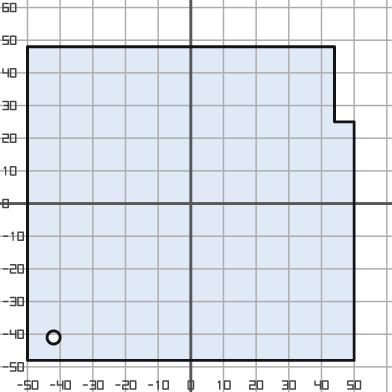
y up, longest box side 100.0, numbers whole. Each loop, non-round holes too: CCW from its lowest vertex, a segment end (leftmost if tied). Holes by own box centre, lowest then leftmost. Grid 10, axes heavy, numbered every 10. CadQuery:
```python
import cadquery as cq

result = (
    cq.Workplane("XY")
    .moveTo(-50.0, -48.0)
    .lineTo(50.0, -48.0)
    .lineTo(50.0, 25.0)
    .lineTo(44.0, 25.0)
    .lineTo(44.0, 48.0)
    .lineTo(-50.0, 48.0)
    .close()
    .moveTo(-42.0, -41.0)
    .circle(2.0)
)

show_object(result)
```